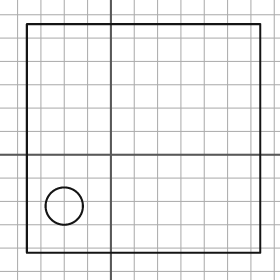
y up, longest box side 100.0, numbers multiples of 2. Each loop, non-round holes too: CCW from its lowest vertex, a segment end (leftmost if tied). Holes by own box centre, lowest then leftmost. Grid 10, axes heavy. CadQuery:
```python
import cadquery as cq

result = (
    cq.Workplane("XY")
    .moveTo(-36.0, -42.0)
    .lineTo(64.0, -42.0)
    .lineTo(64.0, 56.0)
    .lineTo(-36.0, 56.0)
    .close()
    .moveTo(-20.0, -22.0)
    .circle(8.0)
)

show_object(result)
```